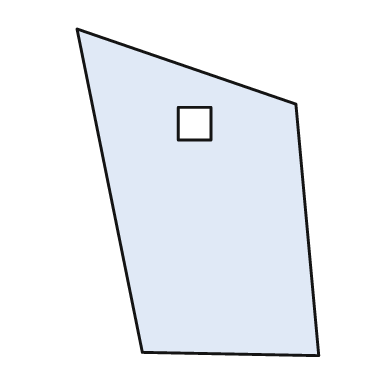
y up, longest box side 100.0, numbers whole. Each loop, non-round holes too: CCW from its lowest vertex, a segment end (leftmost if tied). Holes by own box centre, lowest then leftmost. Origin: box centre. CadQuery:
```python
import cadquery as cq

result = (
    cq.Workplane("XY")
    .moveTo(37.0, -50.0)
    .lineTo(30.0, 27.0)
    .lineTo(-37.0, 50.0)
    .lineTo(-17.0, -49.0)
    .close()
    .moveTo(-6.0, 16.0)
    .lineTo(4.0, 16.0)
    .lineTo(4.0, 26.0)
    .lineTo(-6.0, 26.0)
    .close()
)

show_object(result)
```